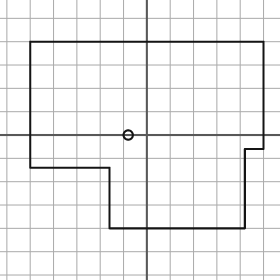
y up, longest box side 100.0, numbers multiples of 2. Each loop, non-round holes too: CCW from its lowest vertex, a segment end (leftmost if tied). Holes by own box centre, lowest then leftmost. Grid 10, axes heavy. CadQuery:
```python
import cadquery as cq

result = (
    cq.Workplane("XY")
    .moveTo(-16.0, -40.0)
    .lineTo(42.0, -40.0)
    .lineTo(42.0, -6.0)
    .lineTo(50.0, -6.0)
    .lineTo(50.0, 40.0)
    .lineTo(-50.0, 40.0)
    .lineTo(-50.0, -14.0)
    .lineTo(-16.0, -14.0)
    .close()
    .moveTo(-8.0, 0.0)
    .circle(2.0)
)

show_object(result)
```